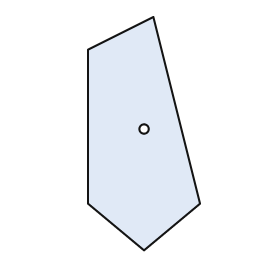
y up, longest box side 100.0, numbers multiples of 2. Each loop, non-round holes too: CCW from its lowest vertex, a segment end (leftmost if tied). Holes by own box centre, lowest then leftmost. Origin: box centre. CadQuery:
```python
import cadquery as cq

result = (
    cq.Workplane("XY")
    .moveTo(0.0, -50.0)
    .lineTo(24.0, -30.0)
    .lineTo(4.0, 50.0)
    .lineTo(-24.0, 36.0)
    .lineTo(-24.0, -30.0)
    .close()
    .moveTo(0.0, 2.0)
    .circle(2.0)
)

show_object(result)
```